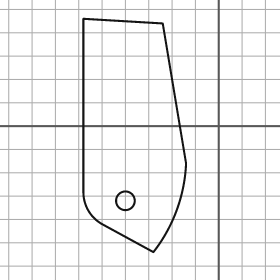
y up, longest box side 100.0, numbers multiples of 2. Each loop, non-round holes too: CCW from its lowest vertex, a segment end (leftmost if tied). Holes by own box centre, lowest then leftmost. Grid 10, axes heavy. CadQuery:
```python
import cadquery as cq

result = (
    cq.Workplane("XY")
    .moveTo(-28.0, -54.0)
    .threePointArc((-18.0, -36.0), (-14.0, -16.0))
    .lineTo(-24.0, 44.0)
    .lineTo(-58.0, 46.0)
    .lineTo(-58.0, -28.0)
    .threePointArc((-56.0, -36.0), (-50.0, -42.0))
    .close()
    .moveTo(-40.0, -32.0)
    .circle(4.0)
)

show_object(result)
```